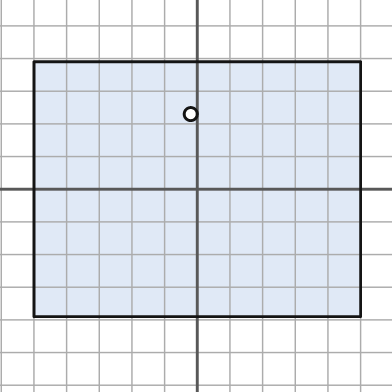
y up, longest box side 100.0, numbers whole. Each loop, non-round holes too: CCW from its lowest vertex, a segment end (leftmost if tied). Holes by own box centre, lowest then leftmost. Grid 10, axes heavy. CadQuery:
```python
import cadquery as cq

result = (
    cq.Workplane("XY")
    .moveTo(-50.0, -39.0)
    .lineTo(50.0, -39.0)
    .lineTo(50.0, 39.0)
    .lineTo(-50.0, 39.0)
    .close()
    .moveTo(-2.0, 23.0)
    .circle(2.0)
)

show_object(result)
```